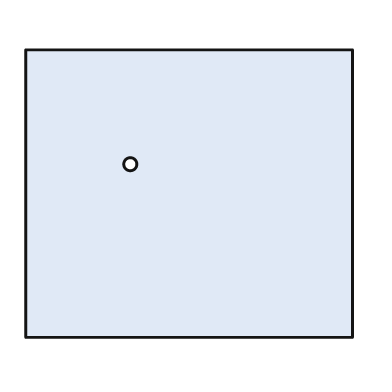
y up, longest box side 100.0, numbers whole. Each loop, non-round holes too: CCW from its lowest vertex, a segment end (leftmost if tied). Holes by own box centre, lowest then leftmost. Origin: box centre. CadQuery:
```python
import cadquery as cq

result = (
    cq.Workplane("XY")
    .moveTo(-50.0, -44.0)
    .lineTo(50.0, -44.0)
    .lineTo(50.0, 44.0)
    .lineTo(-50.0, 44.0)
    .close()
    .moveTo(-18.0, 9.0)
    .circle(2.0)
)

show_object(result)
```